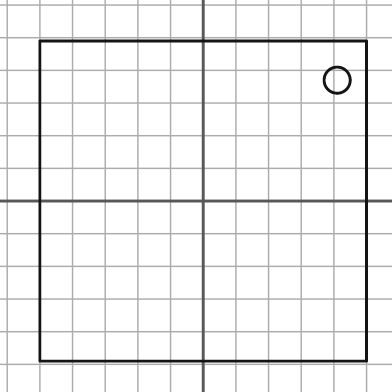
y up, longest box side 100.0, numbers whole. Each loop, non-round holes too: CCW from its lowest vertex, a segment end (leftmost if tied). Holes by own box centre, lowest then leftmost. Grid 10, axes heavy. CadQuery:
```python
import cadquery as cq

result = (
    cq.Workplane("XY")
    .moveTo(-50.0, -49.0)
    .lineTo(50.0, -49.0)
    .lineTo(50.0, 49.0)
    .lineTo(-50.0, 49.0)
    .close()
    .moveTo(41.0, 37.0)
    .circle(4.0)
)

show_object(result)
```